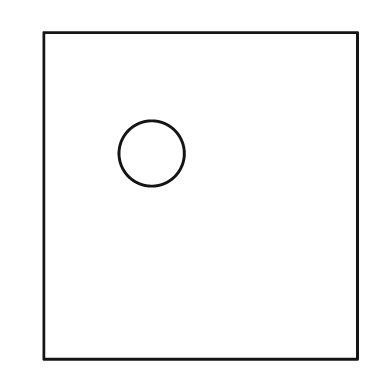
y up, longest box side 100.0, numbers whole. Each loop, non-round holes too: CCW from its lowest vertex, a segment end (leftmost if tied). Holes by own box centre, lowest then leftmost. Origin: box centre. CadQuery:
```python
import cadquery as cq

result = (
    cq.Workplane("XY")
    .moveTo(-48.0, -50.0)
    .lineTo(48.0, -50.0)
    .lineTo(48.0, 50.0)
    .lineTo(-48.0, 50.0)
    .close()
    .moveTo(-15.0, 13.0)
    .circle(10.0)
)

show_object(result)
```